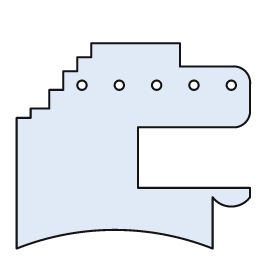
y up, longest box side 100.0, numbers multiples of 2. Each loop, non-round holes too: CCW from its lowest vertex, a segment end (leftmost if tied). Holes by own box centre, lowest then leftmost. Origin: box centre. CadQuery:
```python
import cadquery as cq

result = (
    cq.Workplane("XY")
    .moveTo(-50.0, -44.0)
    .threePointArc((-8.0, -36.0), (34.0, -44.0))
    .lineTo(34.0, -22.0)
    .threePointArc((42.0, -26.0), (50.0, -22.0))
    .lineTo(50.0, -18.0)
    .lineTo(2.0, -18.0)
    .lineTo(2.0, 8.0)
    .lineTo(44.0, 8.0)
    .threePointArc((48.0, 10.0), (50.0, 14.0))
    .lineTo(50.0, 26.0)
    .threePointArc((48.0, 32.0), (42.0, 34.0))
    .lineTo(20.0, 34.0)
    .lineTo(20.0, 44.0)
    .lineTo(-18.0, 44.0)
    .lineTo(-18.0, 38.0)
    .lineTo(-24.0, 38.0)
    .lineTo(-24.0, 32.0)
    .lineTo(-30.0, 32.0)
    .lineTo(-30.0, 24.0)
    .lineTo(-36.0, 24.0)
    .lineTo(-36.0, 16.0)
    .lineTo(-44.0, 16.0)
    .lineTo(-44.0, 12.0)
    .lineTo(-50.0, 12.0)
    .close()
    .moveTo(-22.0, 26.0)
    .circle(2.0)
    .moveTo(-6.0, 26.0)
    .circle(2.0)
    .moveTo(10.0, 26.0)
    .circle(2.0)
    .moveTo(26.0, 26.0)
    .circle(2.0)
    .moveTo(42.0, 26.0)
    .circle(2.0)
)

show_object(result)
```